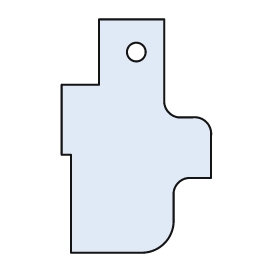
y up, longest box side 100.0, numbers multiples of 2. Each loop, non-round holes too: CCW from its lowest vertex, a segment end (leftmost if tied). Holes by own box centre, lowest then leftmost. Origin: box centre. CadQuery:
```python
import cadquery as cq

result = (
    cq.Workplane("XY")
    .moveTo(-28.0, -50.0)
    .lineTo(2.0, -50.0)
    .threePointArc((12.0, -46.0), (16.0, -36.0))
    .lineTo(16.0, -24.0)
    .threePointArc((18.0, -20.0), (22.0, -18.0))
    .lineTo(32.0, -18.0)
    .lineTo(32.0, 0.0)
    .threePointArc((30.0, 6.0), (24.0, 8.0))
    .lineTo(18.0, 8.0)
    .threePointArc((14.0, 10.0), (12.0, 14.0))
    .lineTo(12.0, 50.0)
    .lineTo(-16.0, 50.0)
    .lineTo(-16.0, 22.0)
    .lineTo(-32.0, 22.0)
    .lineTo(-32.0, -8.0)
    .lineTo(-28.0, -8.0)
    .close()
    .moveTo(0.0, 36.0)
    .circle(4.0)
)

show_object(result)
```